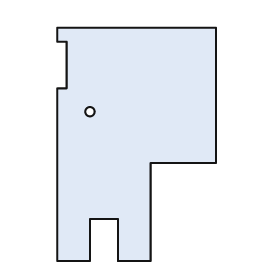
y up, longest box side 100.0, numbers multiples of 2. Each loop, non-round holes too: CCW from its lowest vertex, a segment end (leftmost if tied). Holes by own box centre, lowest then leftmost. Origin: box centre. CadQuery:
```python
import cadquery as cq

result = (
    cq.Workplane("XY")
    .moveTo(-34.0, -50.0)
    .lineTo(-20.0, -50.0)
    .lineTo(-20.0, -32.0)
    .lineTo(-8.0, -32.0)
    .lineTo(-8.0, -50.0)
    .lineTo(6.0, -50.0)
    .lineTo(6.0, -8.0)
    .lineTo(34.0, -8.0)
    .lineTo(34.0, 50.0)
    .lineTo(-34.0, 50.0)
    .lineTo(-34.0, 44.0)
    .lineTo(-30.0, 44.0)
    .lineTo(-30.0, 24.0)
    .lineTo(-34.0, 24.0)
    .close()
    .moveTo(-20.0, 14.0)
    .circle(2.0)
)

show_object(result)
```